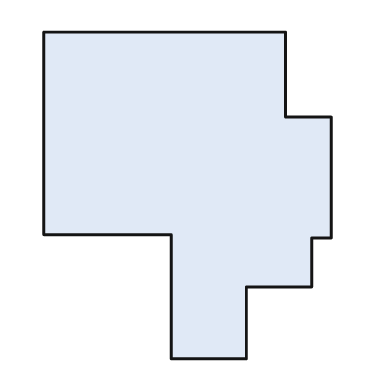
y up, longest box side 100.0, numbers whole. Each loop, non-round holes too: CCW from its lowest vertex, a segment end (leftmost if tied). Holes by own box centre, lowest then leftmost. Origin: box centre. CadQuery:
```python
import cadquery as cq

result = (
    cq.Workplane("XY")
    .moveTo(-5.0, -50.0)
    .lineTo(18.0, -50.0)
    .lineTo(18.0, -28.0)
    .lineTo(38.0, -28.0)
    .lineTo(38.0, -13.0)
    .lineTo(44.0, -13.0)
    .lineTo(44.0, 24.0)
    .lineTo(30.0, 24.0)
    .lineTo(30.0, 50.0)
    .lineTo(-44.0, 50.0)
    .lineTo(-44.0, -12.0)
    .lineTo(-5.0, -12.0)
    .close()
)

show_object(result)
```